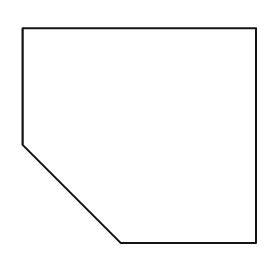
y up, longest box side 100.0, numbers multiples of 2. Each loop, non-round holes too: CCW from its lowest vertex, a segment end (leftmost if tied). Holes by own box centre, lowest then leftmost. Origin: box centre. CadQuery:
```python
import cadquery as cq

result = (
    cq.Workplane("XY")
    .moveTo(-8.0, -46.0)
    .lineTo(50.0, -46.0)
    .lineTo(50.0, 46.0)
    .lineTo(-50.0, 46.0)
    .lineTo(-50.0, -4.0)
    .close()
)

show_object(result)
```